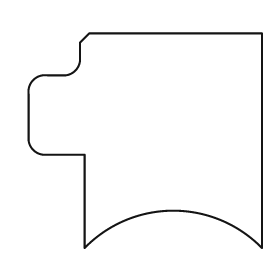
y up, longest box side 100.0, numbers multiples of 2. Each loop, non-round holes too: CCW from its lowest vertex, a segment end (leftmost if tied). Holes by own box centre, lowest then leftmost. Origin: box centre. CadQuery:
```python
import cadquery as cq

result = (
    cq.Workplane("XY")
    .moveTo(-26.0, -46.0)
    .threePointArc((12.0, -30.0), (50.0, -46.0))
    .lineTo(50.0, 46.0)
    .lineTo(-24.0, 46.0)
    .lineTo(-28.0, 42.0)
    .lineTo(-28.0, 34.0)
    .threePointArc((-30.0, 30.0), (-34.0, 28.0))
    .lineTo(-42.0, 28.0)
    .threePointArc((-48.0, 26.0), (-50.0, 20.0))
    .lineTo(-50.0, 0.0)
    .threePointArc((-48.0, -4.0), (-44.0, -6.0))
    .lineTo(-26.0, -6.0)
    .close()
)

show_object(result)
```